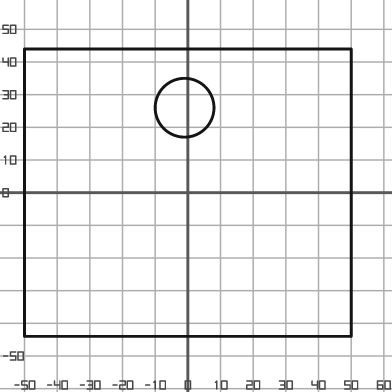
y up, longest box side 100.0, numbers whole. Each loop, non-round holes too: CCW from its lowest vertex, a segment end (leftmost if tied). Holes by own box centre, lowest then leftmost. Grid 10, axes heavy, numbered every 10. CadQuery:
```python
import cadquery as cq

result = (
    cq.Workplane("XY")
    .moveTo(-50.0, -44.0)
    .lineTo(50.0, -44.0)
    .lineTo(50.0, 44.0)
    .lineTo(-50.0, 44.0)
    .close()
    .moveTo(-1.0, 26.0)
    .circle(9.0)
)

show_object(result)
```